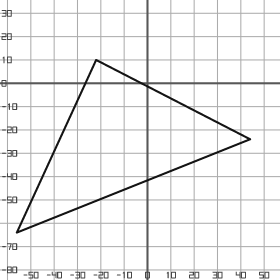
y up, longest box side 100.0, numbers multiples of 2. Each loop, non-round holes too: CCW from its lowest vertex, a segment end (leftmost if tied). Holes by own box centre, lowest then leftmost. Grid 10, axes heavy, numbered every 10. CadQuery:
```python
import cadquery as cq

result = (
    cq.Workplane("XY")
    .moveTo(-56.0, -64.0)
    .lineTo(44.0, -24.0)
    .lineTo(-22.0, 10.0)
    .close()
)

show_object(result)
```